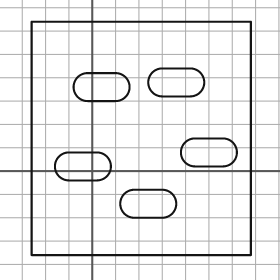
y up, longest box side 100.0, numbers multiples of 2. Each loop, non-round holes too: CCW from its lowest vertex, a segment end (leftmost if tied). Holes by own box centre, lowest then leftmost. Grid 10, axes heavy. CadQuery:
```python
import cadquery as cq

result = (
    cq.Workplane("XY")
    .moveTo(-26.0, -36.0)
    .lineTo(68.0, -36.0)
    .lineTo(68.0, 64.0)
    .lineTo(-26.0, 64.0)
    .close()
    .moveTo(18.0, -20.0)
    .lineTo(30.0, -20.0)
    .threePointArc((36.0, -14.0), (30.0, -8.0))
    .lineTo(18.0, -8.0)
    .threePointArc((12.0, -14.0), (18.0, -20.0))
    .close()
    .moveTo(-10.0, -4.0)
    .lineTo(2.0, -4.0)
    .threePointArc((8.0, 2.0), (2.0, 8.0))
    .lineTo(-10.0, 8.0)
    .threePointArc((-16.0, 2.0), (-10.0, -4.0))
    .close()
    .moveTo(44.0, 2.0)
    .lineTo(56.0, 2.0)
    .threePointArc((62.0, 8.0), (56.0, 14.0))
    .lineTo(44.0, 14.0)
    .threePointArc((38.0, 8.0), (44.0, 2.0))
    .close()
    .moveTo(-2.0, 30.0)
    .lineTo(10.0, 30.0)
    .threePointArc((16.0, 36.0), (10.0, 42.0))
    .lineTo(-2.0, 42.0)
    .threePointArc((-8.0, 36.0), (-2.0, 30.0))
    .close()
    .moveTo(30.0, 32.0)
    .lineTo(42.0, 32.0)
    .threePointArc((48.0, 38.0), (42.0, 44.0))
    .lineTo(30.0, 44.0)
    .threePointArc((24.0, 38.0), (30.0, 32.0))
    .close()
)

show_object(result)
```